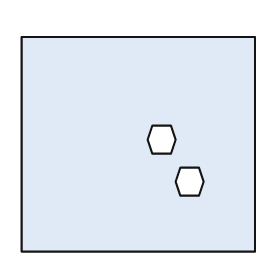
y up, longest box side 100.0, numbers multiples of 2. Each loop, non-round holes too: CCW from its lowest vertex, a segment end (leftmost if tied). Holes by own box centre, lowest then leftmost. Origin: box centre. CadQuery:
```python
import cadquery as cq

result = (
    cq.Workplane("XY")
    .moveTo(-50.0, -46.0)
    .lineTo(50.0, -46.0)
    .lineTo(50.0, 46.0)
    .lineTo(-50.0, 46.0)
    .close()
    .moveTo(18.0, -22.0)
    .lineTo(26.0, -22.0)
    .lineTo(28.0, -16.0)
    .lineTo(26.0, -10.0)
    .lineTo(18.0, -10.0)
    .lineTo(16.0, -16.0)
    .close()
    .moveTo(6.0, -4.0)
    .lineTo(14.0, -4.0)
    .lineTo(16.0, 2.0)
    .lineTo(14.0, 8.0)
    .lineTo(6.0, 8.0)
    .lineTo(4.0, 2.0)
    .close()
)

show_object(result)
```